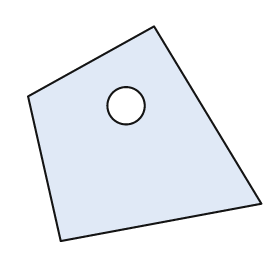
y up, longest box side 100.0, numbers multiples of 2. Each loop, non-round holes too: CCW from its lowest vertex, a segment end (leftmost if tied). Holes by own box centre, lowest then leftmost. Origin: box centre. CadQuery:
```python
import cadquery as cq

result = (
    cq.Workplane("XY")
    .moveTo(-36.0, -46.0)
    .lineTo(50.0, -30.0)
    .lineTo(4.0, 46.0)
    .lineTo(-50.0, 16.0)
    .close()
    .moveTo(-8.0, 12.0)
    .circle(8.0)
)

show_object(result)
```